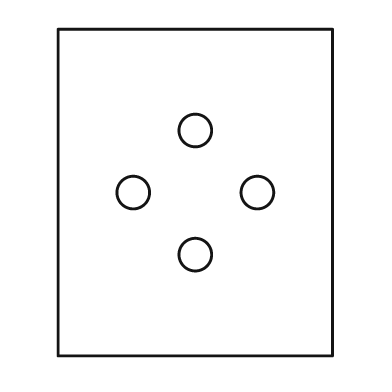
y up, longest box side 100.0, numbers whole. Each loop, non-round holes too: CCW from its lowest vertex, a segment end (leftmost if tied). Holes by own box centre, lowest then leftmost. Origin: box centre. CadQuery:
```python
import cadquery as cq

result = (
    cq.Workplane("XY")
    .moveTo(-42.0, -50.0)
    .lineTo(42.0, -50.0)
    .lineTo(42.0, 50.0)
    .lineTo(-42.0, 50.0)
    .close()
    .moveTo(0.0, -19.0)
    .circle(5.0)
    .moveTo(-19.0, 0.0)
    .circle(5.0)
    .moveTo(19.0, 0.0)
    .circle(5.0)
    .moveTo(0.0, 19.0)
    .circle(5.0)
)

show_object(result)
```